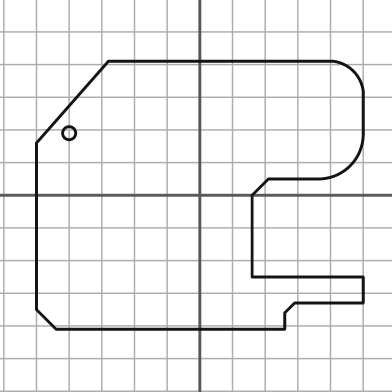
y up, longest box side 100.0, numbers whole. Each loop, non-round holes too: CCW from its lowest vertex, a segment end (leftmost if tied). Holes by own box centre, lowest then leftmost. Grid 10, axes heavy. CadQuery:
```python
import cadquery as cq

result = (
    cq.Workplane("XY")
    .moveTo(-44.0, -41.0)
    .lineTo(26.0, -41.0)
    .lineTo(26.0, -36.0)
    .lineTo(29.0, -33.0)
    .lineTo(50.0, -33.0)
    .lineTo(50.0, -25.0)
    .lineTo(16.0, -25.0)
    .lineTo(16.0, 0.0)
    .lineTo(21.0, 5.0)
    .lineTo(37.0, 5.0)
    .threePointArc((46.0, 9.0), (50.0, 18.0))
    .lineTo(50.0, 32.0)
    .threePointArc((47.0, 38.0), (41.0, 41.0))
    .lineTo(-28.0, 41.0)
    .lineTo(-50.0, 16.0)
    .lineTo(-50.0, -35.0)
    .close()
    .moveTo(-40.0, 19.0)
    .circle(2.0)
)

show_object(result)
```